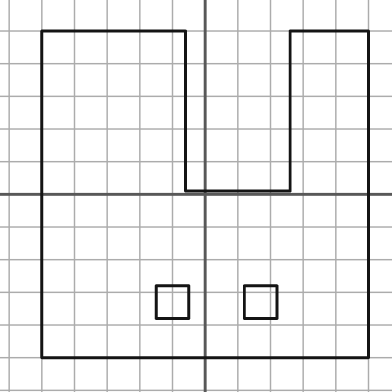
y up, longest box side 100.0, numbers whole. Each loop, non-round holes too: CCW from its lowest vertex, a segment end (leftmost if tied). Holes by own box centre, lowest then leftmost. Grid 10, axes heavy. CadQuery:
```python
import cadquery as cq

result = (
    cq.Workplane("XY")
    .moveTo(-50.0, -50.0)
    .lineTo(50.0, -50.0)
    .lineTo(50.0, 50.0)
    .lineTo(26.0, 50.0)
    .lineTo(26.0, 1.0)
    .lineTo(-6.0, 1.0)
    .lineTo(-6.0, 50.0)
    .lineTo(-50.0, 50.0)
    .close()
    .moveTo(-15.0, -38.0)
    .lineTo(-5.0, -38.0)
    .lineTo(-5.0, -28.0)
    .lineTo(-15.0, -28.0)
    .close()
    .moveTo(12.0, -38.0)
    .lineTo(22.0, -38.0)
    .lineTo(22.0, -28.0)
    .lineTo(12.0, -28.0)
    .close()
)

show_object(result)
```